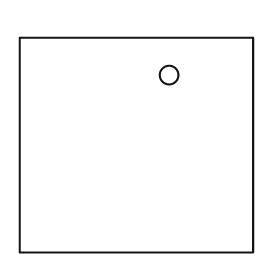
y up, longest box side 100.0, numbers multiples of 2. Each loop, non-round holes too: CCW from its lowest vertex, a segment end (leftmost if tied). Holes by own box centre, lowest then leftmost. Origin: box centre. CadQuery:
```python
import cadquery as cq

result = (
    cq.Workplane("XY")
    .moveTo(-50.0, -46.0)
    .lineTo(50.0, -46.0)
    .lineTo(50.0, 46.0)
    .lineTo(-50.0, 46.0)
    .close()
    .moveTo(14.0, 30.0)
    .circle(4.0)
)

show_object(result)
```